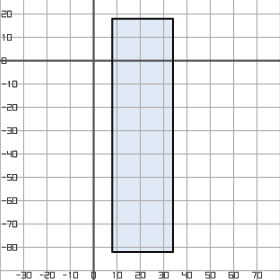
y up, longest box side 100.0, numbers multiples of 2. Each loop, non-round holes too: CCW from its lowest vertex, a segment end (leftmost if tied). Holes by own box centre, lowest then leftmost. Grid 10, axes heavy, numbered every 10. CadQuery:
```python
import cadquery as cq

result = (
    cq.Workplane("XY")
    .moveTo(8.0, -82.0)
    .lineTo(34.0, -82.0)
    .lineTo(34.0, 18.0)
    .lineTo(8.0, 18.0)
    .close()
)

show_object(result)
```